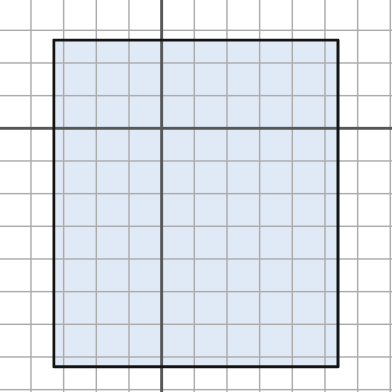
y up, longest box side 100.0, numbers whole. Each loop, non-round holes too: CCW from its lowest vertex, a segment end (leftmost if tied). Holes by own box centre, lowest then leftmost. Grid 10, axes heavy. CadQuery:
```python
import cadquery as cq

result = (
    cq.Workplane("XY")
    .moveTo(-33.0, -73.0)
    .lineTo(54.0, -73.0)
    .lineTo(54.0, 27.0)
    .lineTo(-33.0, 27.0)
    .close()
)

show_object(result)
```